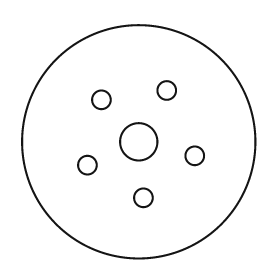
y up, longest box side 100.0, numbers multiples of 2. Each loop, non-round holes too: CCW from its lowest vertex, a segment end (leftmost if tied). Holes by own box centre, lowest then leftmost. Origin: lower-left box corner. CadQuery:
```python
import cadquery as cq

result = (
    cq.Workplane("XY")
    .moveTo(50.0, 50.0)
    .circle(50.0)
    .moveTo(52.0, 26.0)
    .circle(4.0)
    .moveTo(28.0, 40.0)
    .circle(4.0)
    .moveTo(74.0, 44.0)
    .circle(4.0)
    .moveTo(50.0, 50.0)
    .circle(8.0)
    .moveTo(34.0, 68.0)
    .circle(4.0)
    .moveTo(62.0, 72.0)
    .circle(4.0)
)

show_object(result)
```